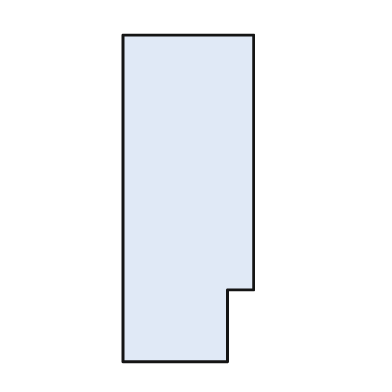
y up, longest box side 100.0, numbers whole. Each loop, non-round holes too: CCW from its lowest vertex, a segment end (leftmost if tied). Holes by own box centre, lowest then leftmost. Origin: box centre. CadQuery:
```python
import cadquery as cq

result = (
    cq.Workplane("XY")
    .moveTo(-20.0, -50.0)
    .lineTo(12.0, -50.0)
    .lineTo(12.0, -28.0)
    .lineTo(20.0, -28.0)
    .lineTo(20.0, 50.0)
    .lineTo(-20.0, 50.0)
    .close()
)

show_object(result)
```